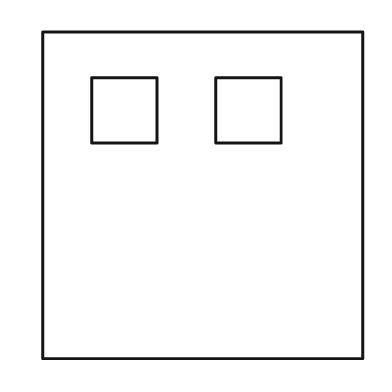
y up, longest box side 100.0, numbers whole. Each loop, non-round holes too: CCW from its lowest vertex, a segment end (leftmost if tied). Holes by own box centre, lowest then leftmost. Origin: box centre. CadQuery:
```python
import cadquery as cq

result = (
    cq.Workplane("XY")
    .moveTo(-49.0, -50.0)
    .lineTo(49.0, -50.0)
    .lineTo(49.0, 50.0)
    .lineTo(-49.0, 50.0)
    .close()
    .moveTo(-34.0, 16.0)
    .lineTo(-14.0, 16.0)
    .lineTo(-14.0, 36.0)
    .lineTo(-34.0, 36.0)
    .close()
    .moveTo(4.0, 16.0)
    .lineTo(24.0, 16.0)
    .lineTo(24.0, 36.0)
    .lineTo(4.0, 36.0)
    .close()
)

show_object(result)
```